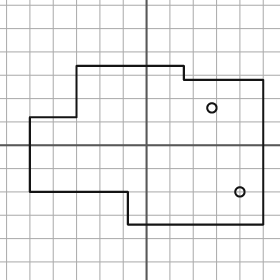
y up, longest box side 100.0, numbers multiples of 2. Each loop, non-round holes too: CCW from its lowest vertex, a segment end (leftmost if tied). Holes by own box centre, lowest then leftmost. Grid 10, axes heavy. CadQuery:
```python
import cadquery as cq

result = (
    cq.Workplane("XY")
    .moveTo(-8.0, -34.0)
    .lineTo(50.0, -34.0)
    .lineTo(50.0, 28.0)
    .lineTo(16.0, 28.0)
    .lineTo(16.0, 34.0)
    .lineTo(-30.0, 34.0)
    .lineTo(-30.0, 12.0)
    .lineTo(-50.0, 12.0)
    .lineTo(-50.0, -20.0)
    .lineTo(-8.0, -20.0)
    .close()
    .moveTo(40.0, -20.0)
    .circle(2.0)
    .moveTo(28.0, 16.0)
    .circle(2.0)
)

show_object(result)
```